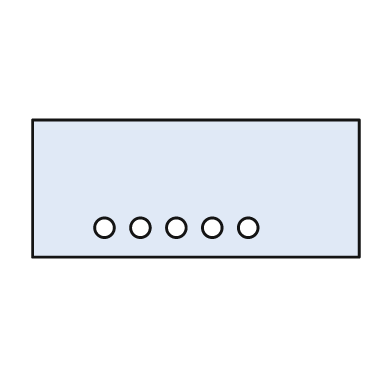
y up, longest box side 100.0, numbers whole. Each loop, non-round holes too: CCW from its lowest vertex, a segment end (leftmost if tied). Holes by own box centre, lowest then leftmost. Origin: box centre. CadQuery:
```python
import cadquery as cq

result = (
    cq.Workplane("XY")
    .moveTo(-50.0, -21.0)
    .lineTo(50.0, -21.0)
    .lineTo(50.0, 21.0)
    .lineTo(-50.0, 21.0)
    .close()
    .moveTo(-28.0, -12.0)
    .circle(3.0)
    .moveTo(-17.0, -12.0)
    .circle(3.0)
    .moveTo(-6.0, -12.0)
    .circle(3.0)
    .moveTo(5.0, -12.0)
    .circle(3.0)
    .moveTo(16.0, -12.0)
    .circle(3.0)
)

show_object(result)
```